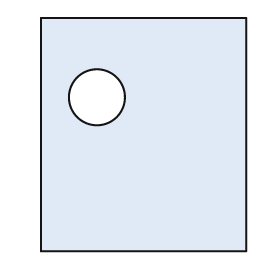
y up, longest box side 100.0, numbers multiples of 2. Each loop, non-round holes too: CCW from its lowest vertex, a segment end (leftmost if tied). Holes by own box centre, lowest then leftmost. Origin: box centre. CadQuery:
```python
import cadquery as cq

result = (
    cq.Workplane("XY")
    .moveTo(-44.0, -50.0)
    .lineTo(44.0, -50.0)
    .lineTo(44.0, 50.0)
    .lineTo(-44.0, 50.0)
    .close()
    .moveTo(-20.0, 16.0)
    .circle(12.0)
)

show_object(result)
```